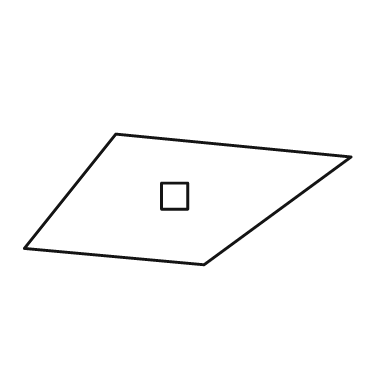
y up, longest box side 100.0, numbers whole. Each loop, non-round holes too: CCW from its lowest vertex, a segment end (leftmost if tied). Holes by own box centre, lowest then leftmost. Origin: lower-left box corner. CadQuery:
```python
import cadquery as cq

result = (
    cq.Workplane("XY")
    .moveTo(55.0, 0.0)
    .lineTo(100.0, 33.0)
    .lineTo(28.0, 40.0)
    .lineTo(0.0, 5.0)
    .close()
    .moveTo(42.0, 17.0)
    .lineTo(50.0, 17.0)
    .lineTo(50.0, 25.0)
    .lineTo(42.0, 25.0)
    .close()
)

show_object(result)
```